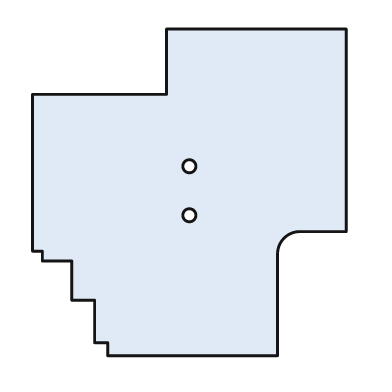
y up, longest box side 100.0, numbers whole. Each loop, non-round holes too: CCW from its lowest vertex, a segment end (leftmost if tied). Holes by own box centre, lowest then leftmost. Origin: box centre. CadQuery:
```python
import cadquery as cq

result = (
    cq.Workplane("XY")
    .moveTo(-25.0, -50.0)
    .lineTo(27.0, -50.0)
    .lineTo(27.0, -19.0)
    .threePointArc((29.0, -14.0), (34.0, -12.0))
    .lineTo(48.0, -12.0)
    .lineTo(48.0, 50.0)
    .lineTo(-7.0, 50.0)
    .lineTo(-7.0, 30.0)
    .lineTo(-48.0, 30.0)
    .lineTo(-48.0, -18.0)
    .lineTo(-45.0, -18.0)
    .lineTo(-45.0, -21.0)
    .lineTo(-36.0, -21.0)
    .lineTo(-36.0, -33.0)
    .lineTo(-29.0, -33.0)
    .lineTo(-29.0, -46.0)
    .lineTo(-25.0, -46.0)
    .close()
    .moveTo(0.0, -7.0)
    .circle(2.0)
    .moveTo(0.0, 8.0)
    .circle(2.0)
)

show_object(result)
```